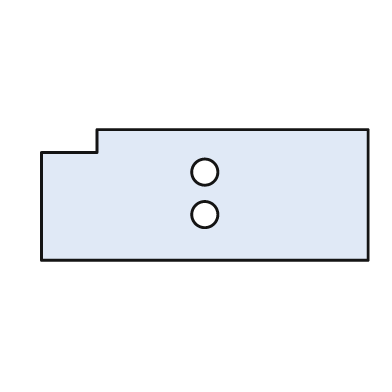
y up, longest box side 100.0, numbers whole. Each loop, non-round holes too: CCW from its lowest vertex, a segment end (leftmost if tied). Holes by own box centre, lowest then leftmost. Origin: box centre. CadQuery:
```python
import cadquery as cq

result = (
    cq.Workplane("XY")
    .moveTo(-50.0, -20.0)
    .lineTo(50.0, -20.0)
    .lineTo(50.0, 20.0)
    .lineTo(-33.0, 20.0)
    .lineTo(-33.0, 13.0)
    .lineTo(-50.0, 13.0)
    .close()
    .moveTo(0.0, -6.0)
    .circle(4.0)
    .moveTo(0.0, 7.0)
    .circle(4.0)
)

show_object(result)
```